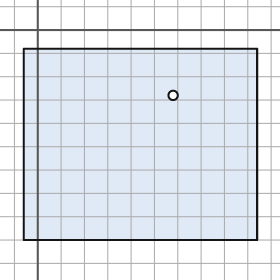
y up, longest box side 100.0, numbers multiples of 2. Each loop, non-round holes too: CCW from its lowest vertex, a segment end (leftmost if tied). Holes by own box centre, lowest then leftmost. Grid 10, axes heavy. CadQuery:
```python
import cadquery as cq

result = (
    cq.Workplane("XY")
    .moveTo(-6.0, -90.0)
    .lineTo(94.0, -90.0)
    .lineTo(94.0, -8.0)
    .lineTo(-6.0, -8.0)
    .close()
    .moveTo(58.0, -28.0)
    .circle(2.0)
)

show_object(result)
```